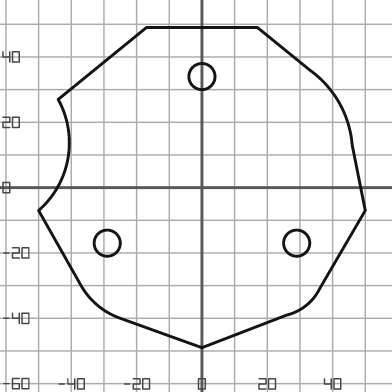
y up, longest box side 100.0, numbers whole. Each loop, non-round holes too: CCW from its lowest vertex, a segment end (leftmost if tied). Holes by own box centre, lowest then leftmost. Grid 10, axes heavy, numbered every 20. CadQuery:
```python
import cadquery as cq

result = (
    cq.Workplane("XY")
    .moveTo(0.0, -49.0)
    .lineTo(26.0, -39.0)
    .threePointArc((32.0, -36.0), (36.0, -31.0))
    .lineTo(50.0, -7.0)
    .lineTo(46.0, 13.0)
    .threePointArc((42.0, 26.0), (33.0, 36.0))
    .lineTo(17.0, 49.0)
    .lineTo(-17.0, 49.0)
    .lineTo(-44.0, 27.0)
    .threePointArc((-41.0, 9.0), (-50.0, -7.0))
    .lineTo(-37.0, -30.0)
    .threePointArc((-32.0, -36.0), (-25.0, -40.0))
    .close()
    .moveTo(-29.0, -17.0)
    .circle(4.0)
    .moveTo(29.0, -17.0)
    .circle(4.0)
    .moveTo(0.0, 34.0)
    .circle(4.0)
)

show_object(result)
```